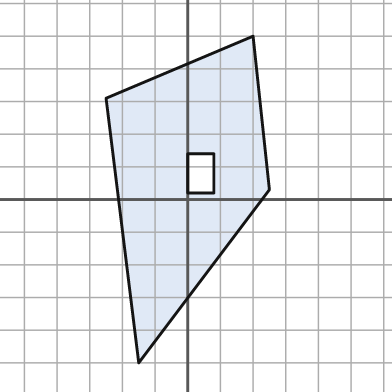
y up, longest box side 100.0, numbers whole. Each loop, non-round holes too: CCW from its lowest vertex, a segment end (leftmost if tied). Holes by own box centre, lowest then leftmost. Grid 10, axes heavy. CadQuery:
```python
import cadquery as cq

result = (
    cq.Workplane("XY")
    .moveTo(-15.0, -50.0)
    .lineTo(25.0, 3.0)
    .lineTo(20.0, 50.0)
    .lineTo(-25.0, 31.0)
    .close()
    .moveTo(0.0, 2.0)
    .lineTo(8.0, 2.0)
    .lineTo(8.0, 14.0)
    .lineTo(0.0, 14.0)
    .close()
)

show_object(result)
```